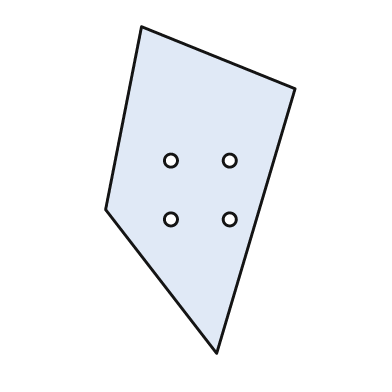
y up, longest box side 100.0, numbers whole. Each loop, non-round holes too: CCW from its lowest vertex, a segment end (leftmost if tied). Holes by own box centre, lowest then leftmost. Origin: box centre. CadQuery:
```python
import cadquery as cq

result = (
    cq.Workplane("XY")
    .moveTo(5.0, -50.0)
    .lineTo(29.0, 31.0)
    .lineTo(-18.0, 50.0)
    .lineTo(-29.0, -6.0)
    .close()
    .moveTo(-9.0, -9.0)
    .circle(2.0)
    .moveTo(9.0, -9.0)
    .circle(2.0)
    .moveTo(-9.0, 9.0)
    .circle(2.0)
    .moveTo(9.0, 9.0)
    .circle(2.0)
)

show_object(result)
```